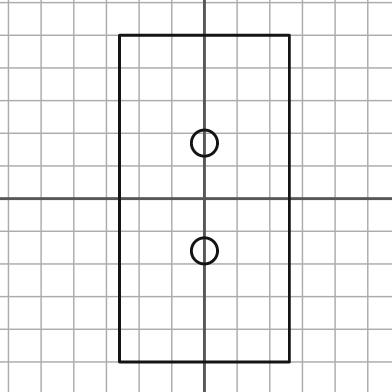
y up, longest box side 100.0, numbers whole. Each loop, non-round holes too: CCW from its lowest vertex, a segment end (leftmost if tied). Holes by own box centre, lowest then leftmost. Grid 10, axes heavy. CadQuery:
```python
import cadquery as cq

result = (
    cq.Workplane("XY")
    .moveTo(-26.0, -50.0)
    .lineTo(26.0, -50.0)
    .lineTo(26.0, 50.0)
    .lineTo(-26.0, 50.0)
    .close()
    .moveTo(0.0, -16.0)
    .circle(4.0)
    .moveTo(0.0, 17.0)
    .circle(4.0)
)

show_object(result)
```